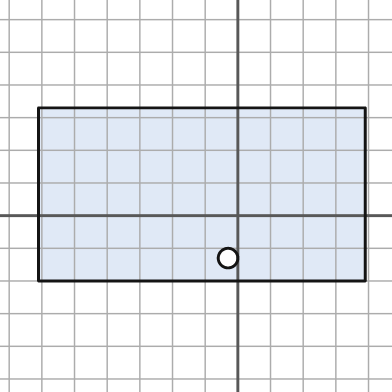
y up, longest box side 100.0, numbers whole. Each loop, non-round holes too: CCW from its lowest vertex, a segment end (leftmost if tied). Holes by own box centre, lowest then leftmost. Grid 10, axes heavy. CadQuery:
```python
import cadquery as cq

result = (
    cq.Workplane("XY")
    .moveTo(-61.0, -20.0)
    .lineTo(39.0, -20.0)
    .lineTo(39.0, 33.0)
    .lineTo(-61.0, 33.0)
    .close()
    .moveTo(-3.0, -13.0)
    .circle(3.0)
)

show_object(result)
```